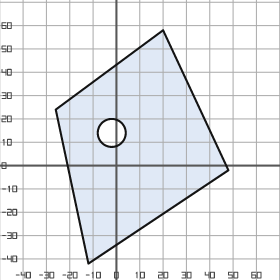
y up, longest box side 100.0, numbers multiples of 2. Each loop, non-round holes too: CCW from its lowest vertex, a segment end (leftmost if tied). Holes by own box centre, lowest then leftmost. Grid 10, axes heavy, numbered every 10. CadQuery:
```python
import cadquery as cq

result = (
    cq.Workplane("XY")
    .moveTo(-12.0, -42.0)
    .lineTo(48.0, -2.0)
    .lineTo(20.0, 58.0)
    .lineTo(-26.0, 24.0)
    .close()
    .moveTo(-2.0, 14.0)
    .circle(6.0)
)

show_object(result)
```